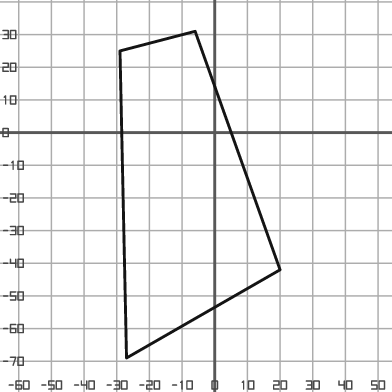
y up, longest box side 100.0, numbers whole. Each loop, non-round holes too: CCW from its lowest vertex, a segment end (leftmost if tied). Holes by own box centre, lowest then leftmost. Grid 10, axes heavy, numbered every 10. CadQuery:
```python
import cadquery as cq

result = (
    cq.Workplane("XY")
    .moveTo(-27.0, -69.0)
    .lineTo(20.0, -42.0)
    .lineTo(-6.0, 31.0)
    .lineTo(-29.0, 25.0)
    .close()
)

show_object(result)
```